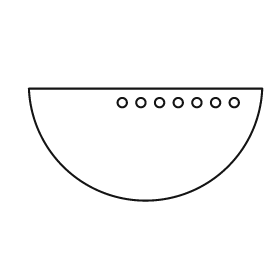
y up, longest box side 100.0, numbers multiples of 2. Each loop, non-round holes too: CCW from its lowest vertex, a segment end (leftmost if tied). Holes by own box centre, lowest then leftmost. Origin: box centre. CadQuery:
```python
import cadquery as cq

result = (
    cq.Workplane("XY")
    .moveTo(-50.0, 24.0)
    .threePointArc((0.0, -24.0), (50.0, 24.0))
    .close()
    .moveTo(-10.0, 18.0)
    .circle(2.0)
    .moveTo(-2.0, 18.0)
    .circle(2.0)
    .moveTo(6.0, 18.0)
    .circle(2.0)
    .moveTo(14.0, 18.0)
    .circle(2.0)
    .moveTo(22.0, 18.0)
    .circle(2.0)
    .moveTo(30.0, 18.0)
    .circle(2.0)
    .moveTo(38.0, 18.0)
    .circle(2.0)
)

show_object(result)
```